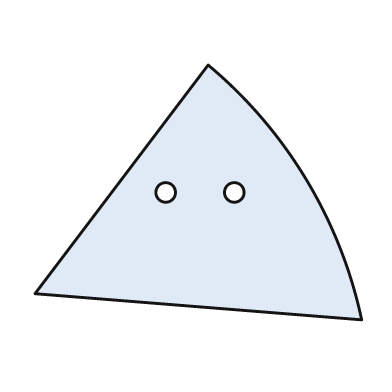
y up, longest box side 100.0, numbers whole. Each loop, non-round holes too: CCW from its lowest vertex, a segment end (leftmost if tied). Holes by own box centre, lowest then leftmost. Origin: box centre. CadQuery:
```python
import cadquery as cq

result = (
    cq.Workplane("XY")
    .moveTo(50.0, -39.0)
    .threePointArc((33.0, 4.0), (3.0, 39.0))
    .lineTo(-50.0, -31.0)
    .close()
    .moveTo(-10.0, 0.0)
    .circle(3.0)
    .moveTo(11.0, 0.0)
    .circle(3.0)
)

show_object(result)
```